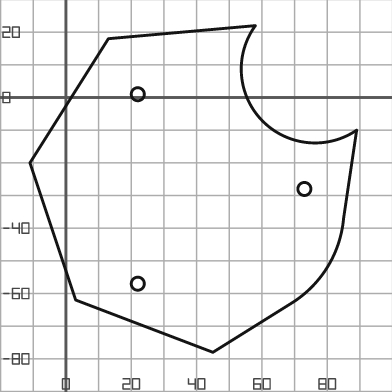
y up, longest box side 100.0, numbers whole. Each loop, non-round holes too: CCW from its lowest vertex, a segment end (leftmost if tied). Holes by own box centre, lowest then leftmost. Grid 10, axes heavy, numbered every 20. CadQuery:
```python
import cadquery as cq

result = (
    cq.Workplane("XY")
    .moveTo(45.0, -78.0)
    .lineTo(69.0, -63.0)
    .threePointArc((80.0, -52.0), (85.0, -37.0))
    .lineTo(89.0, -10.0)
    .threePointArc((60.0, -7.0), (58.0, 22.0))
    .lineTo(13.0, 18.0)
    .lineTo(-11.0, -20.0)
    .lineTo(3.0, -62.0)
    .close()
    .moveTo(22.0, -57.0)
    .circle(2.0)
    .moveTo(73.0, -28.0)
    .circle(2.0)
    .moveTo(22.0, 1.0)
    .circle(2.0)
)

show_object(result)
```